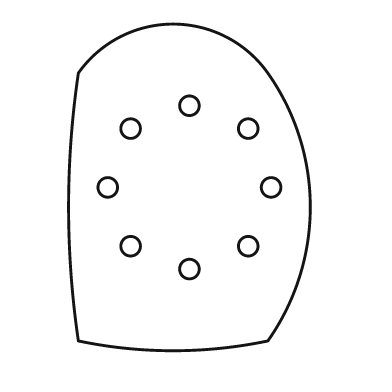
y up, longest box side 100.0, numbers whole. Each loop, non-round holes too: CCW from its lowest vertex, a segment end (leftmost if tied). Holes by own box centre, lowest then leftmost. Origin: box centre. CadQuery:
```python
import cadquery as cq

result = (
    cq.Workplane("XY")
    .moveTo(-34.0, -47.0)
    .threePointArc((-5.0, -50.0), (24.0, -47.0))
    .threePointArc((37.0, -6.0), (24.0, 35.0))
    .threePointArc((-5.0, 50.0), (-34.0, 35.0))
    .threePointArc((-37.0, -6.0), (-34.0, -47.0))
    .close()
    .moveTo(0.0, -25.0)
    .circle(3.0)
    .moveTo(-18.0, -18.0)
    .circle(3.0)
    .moveTo(18.0, -18.0)
    .circle(3.0)
    .moveTo(-25.0, 0.0)
    .circle(3.0)
    .moveTo(25.0, 0.0)
    .circle(3.0)
    .moveTo(-18.0, 18.0)
    .circle(3.0)
    .moveTo(18.0, 18.0)
    .circle(3.0)
    .moveTo(0.0, 25.0)
    .circle(3.0)
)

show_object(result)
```